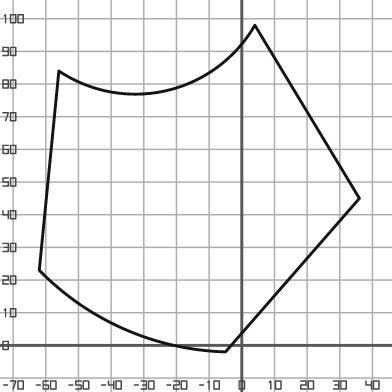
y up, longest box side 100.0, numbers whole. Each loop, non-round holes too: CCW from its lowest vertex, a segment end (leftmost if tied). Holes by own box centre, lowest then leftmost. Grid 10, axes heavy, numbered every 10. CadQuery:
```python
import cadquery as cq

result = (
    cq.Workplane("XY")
    .moveTo(-5.0, -2.0)
    .lineTo(36.0, 45.0)
    .lineTo(4.0, 98.0)
    .threePointArc((-23.0, 78.0), (-56.0, 84.0))
    .lineTo(-62.0, 23.0)
    .threePointArc((-36.0, 5.0), (-5.0, -2.0))
    .close()
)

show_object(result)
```